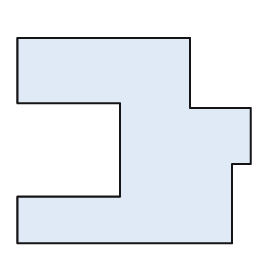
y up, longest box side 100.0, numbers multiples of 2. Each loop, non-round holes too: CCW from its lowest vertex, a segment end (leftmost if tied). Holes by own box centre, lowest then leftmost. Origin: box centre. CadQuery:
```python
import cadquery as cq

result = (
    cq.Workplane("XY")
    .moveTo(-50.0, -44.0)
    .lineTo(42.0, -44.0)
    .lineTo(42.0, -10.0)
    .lineTo(50.0, -10.0)
    .lineTo(50.0, 14.0)
    .lineTo(24.0, 14.0)
    .lineTo(24.0, 44.0)
    .lineTo(-50.0, 44.0)
    .lineTo(-50.0, 16.0)
    .lineTo(-6.0, 16.0)
    .lineTo(-6.0, -24.0)
    .lineTo(-50.0, -24.0)
    .close()
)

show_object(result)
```